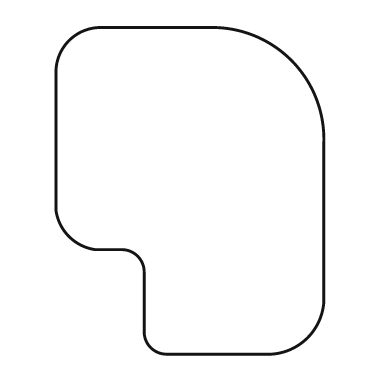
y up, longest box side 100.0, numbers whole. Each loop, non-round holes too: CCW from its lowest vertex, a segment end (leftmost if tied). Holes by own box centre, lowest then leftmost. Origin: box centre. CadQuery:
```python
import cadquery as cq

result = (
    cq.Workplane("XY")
    .moveTo(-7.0, -50.0)
    .lineTo(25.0, -50.0)
    .threePointArc((36.0, -45.0), (41.0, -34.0))
    .lineTo(41.0, 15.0)
    .threePointArc((31.0, 40.0), (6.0, 50.0))
    .lineTo(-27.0, 50.0)
    .threePointArc((-37.0, 46.0), (-41.0, 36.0))
    .lineTo(-41.0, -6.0)
    .threePointArc((-37.0, -14.0), (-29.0, -18.0))
    .lineTo(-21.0, -18.0)
    .threePointArc((-16.0, -20.0), (-14.0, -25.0))
    .lineTo(-14.0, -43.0)
    .threePointArc((-12.0, -48.0), (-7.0, -50.0))
    .close()
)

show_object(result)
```